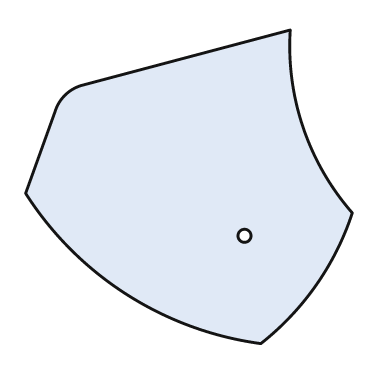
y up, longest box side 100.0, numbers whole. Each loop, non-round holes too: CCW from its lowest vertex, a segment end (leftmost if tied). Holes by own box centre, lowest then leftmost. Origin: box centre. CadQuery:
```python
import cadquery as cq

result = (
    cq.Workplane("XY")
    .moveTo(22.0, -48.0)
    .threePointArc((39.0, -30.0), (50.0, -8.0))
    .threePointArc((35.0, 18.0), (31.0, 48.0))
    .lineTo(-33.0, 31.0)
    .threePointArc((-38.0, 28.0), (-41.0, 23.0))
    .lineTo(-50.0, -2.0)
    .threePointArc((-19.0, -33.0), (22.0, -48.0))
    .close()
    .moveTo(17.0, -15.0)
    .circle(2.0)
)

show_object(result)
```